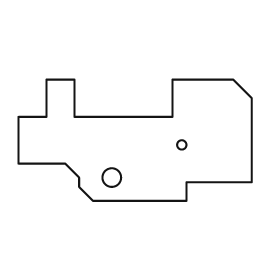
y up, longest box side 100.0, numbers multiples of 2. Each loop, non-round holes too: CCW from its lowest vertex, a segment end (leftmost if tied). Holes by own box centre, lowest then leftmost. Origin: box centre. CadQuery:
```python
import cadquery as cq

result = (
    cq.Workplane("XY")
    .moveTo(-18.0, -26.0)
    .lineTo(22.0, -26.0)
    .lineTo(22.0, -18.0)
    .lineTo(50.0, -18.0)
    .lineTo(50.0, 18.0)
    .lineTo(42.0, 26.0)
    .lineTo(16.0, 26.0)
    .lineTo(16.0, 10.0)
    .lineTo(-26.0, 10.0)
    .lineTo(-26.0, 26.0)
    .lineTo(-38.0, 26.0)
    .lineTo(-38.0, 10.0)
    .lineTo(-50.0, 10.0)
    .lineTo(-50.0, -10.0)
    .lineTo(-30.0, -10.0)
    .lineTo(-24.0, -16.0)
    .lineTo(-24.0, -20.0)
    .close()
    .moveTo(-10.0, -16.0)
    .circle(4.0)
    .moveTo(20.0, -2.0)
    .circle(2.0)
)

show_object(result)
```